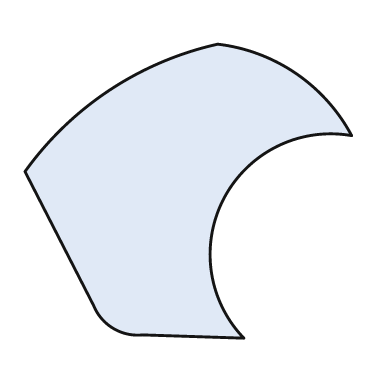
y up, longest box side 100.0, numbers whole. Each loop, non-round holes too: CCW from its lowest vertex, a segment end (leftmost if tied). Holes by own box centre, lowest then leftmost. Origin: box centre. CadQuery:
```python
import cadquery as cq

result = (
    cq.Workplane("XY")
    .moveTo(17.0, -45.0)
    .threePointArc((11.0, -2.0), (50.0, 17.0))
    .threePointArc((33.0, 36.0), (9.0, 45.0))
    .threePointArc((-24.0, 31.0), (-50.0, 6.0))
    .lineTo(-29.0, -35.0)
    .threePointArc((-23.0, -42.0), (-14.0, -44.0))
    .close()
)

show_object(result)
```